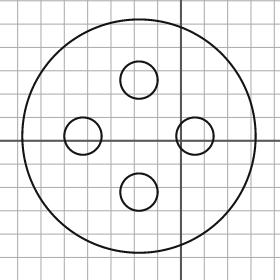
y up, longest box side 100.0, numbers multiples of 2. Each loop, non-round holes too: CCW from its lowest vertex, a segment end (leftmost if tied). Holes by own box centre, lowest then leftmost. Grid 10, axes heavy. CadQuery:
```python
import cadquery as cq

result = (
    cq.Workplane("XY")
    .moveTo(-18.0, 2.0)
    .circle(50.0)
    .moveTo(-18.0, -22.0)
    .circle(8.0)
    .moveTo(-42.0, 2.0)
    .circle(8.0)
    .moveTo(6.0, 2.0)
    .circle(8.0)
    .moveTo(-18.0, 26.0)
    .circle(8.0)
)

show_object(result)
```